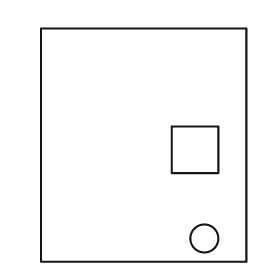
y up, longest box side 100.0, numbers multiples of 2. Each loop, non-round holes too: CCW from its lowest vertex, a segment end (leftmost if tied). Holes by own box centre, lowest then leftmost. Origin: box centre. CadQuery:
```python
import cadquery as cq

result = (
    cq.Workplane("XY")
    .moveTo(-44.0, -50.0)
    .lineTo(44.0, -50.0)
    .lineTo(44.0, 50.0)
    .lineTo(-44.0, 50.0)
    .close()
    .moveTo(26.0, -40.0)
    .circle(6.0)
    .moveTo(12.0, -12.0)
    .lineTo(32.0, -12.0)
    .lineTo(32.0, 8.0)
    .lineTo(12.0, 8.0)
    .close()
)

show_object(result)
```